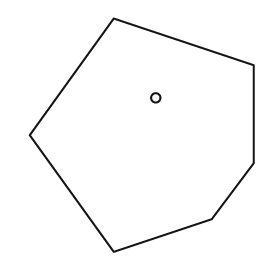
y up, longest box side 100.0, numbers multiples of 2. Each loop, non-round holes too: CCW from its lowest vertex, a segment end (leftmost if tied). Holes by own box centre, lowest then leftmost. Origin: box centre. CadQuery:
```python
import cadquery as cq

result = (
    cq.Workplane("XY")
    .moveTo(-12.0, -50.0)
    .lineTo(30.0, -36.0)
    .lineTo(48.0, -12.0)
    .lineTo(48.0, 30.0)
    .lineTo(-12.0, 50.0)
    .lineTo(-48.0, 0.0)
    .close()
    .moveTo(6.0, 16.0)
    .circle(2.0)
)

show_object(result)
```